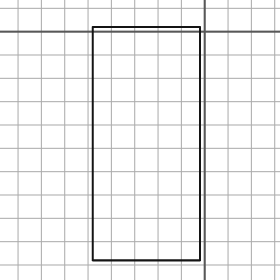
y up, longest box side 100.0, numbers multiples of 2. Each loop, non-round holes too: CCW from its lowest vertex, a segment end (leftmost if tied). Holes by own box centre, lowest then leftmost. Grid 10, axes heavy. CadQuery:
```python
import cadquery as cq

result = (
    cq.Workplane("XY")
    .moveTo(-48.0, -98.0)
    .lineTo(-2.0, -98.0)
    .lineTo(-2.0, 2.0)
    .lineTo(-48.0, 2.0)
    .close()
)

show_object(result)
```